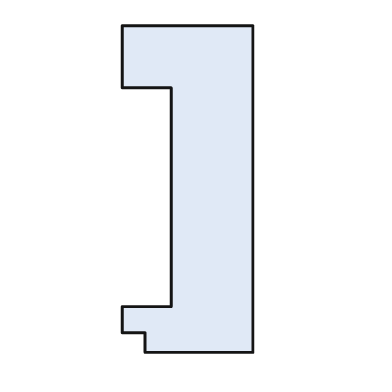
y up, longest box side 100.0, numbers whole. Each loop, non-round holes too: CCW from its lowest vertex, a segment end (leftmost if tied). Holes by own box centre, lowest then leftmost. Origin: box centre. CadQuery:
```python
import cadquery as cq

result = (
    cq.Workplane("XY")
    .moveTo(-13.0, -50.0)
    .lineTo(20.0, -50.0)
    .lineTo(20.0, 50.0)
    .lineTo(-20.0, 50.0)
    .lineTo(-20.0, 31.0)
    .lineTo(-5.0, 31.0)
    .lineTo(-5.0, -36.0)
    .lineTo(-20.0, -36.0)
    .lineTo(-20.0, -44.0)
    .lineTo(-13.0, -44.0)
    .close()
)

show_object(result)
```